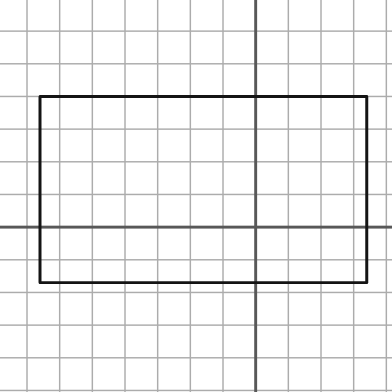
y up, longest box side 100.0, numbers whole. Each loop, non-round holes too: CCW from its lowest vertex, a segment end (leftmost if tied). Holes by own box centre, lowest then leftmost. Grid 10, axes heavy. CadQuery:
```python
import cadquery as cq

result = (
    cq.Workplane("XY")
    .moveTo(-66.0, -17.0)
    .lineTo(34.0, -17.0)
    .lineTo(34.0, 40.0)
    .lineTo(-66.0, 40.0)
    .close()
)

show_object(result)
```